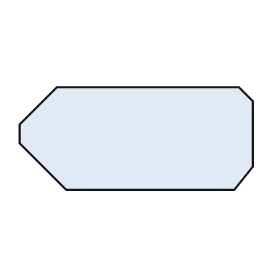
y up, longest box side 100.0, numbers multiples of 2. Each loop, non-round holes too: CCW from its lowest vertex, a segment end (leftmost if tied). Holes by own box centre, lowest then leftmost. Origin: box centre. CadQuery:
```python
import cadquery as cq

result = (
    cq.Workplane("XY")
    .moveTo(-30.0, -22.0)
    .lineTo(42.0, -22.0)
    .lineTo(50.0, -12.0)
    .lineTo(50.0, 16.0)
    .lineTo(44.0, 22.0)
    .lineTo(-34.0, 22.0)
    .lineTo(-50.0, 6.0)
    .lineTo(-50.0, -2.0)
    .close()
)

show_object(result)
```